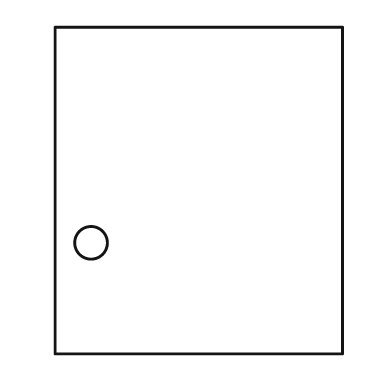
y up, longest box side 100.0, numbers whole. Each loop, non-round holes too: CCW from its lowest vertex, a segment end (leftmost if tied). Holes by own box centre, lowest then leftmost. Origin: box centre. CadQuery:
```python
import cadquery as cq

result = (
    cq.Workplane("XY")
    .moveTo(-44.0, -50.0)
    .lineTo(44.0, -50.0)
    .lineTo(44.0, 50.0)
    .lineTo(-44.0, 50.0)
    .close()
    .moveTo(-33.0, -16.0)
    .circle(5.0)
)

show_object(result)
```